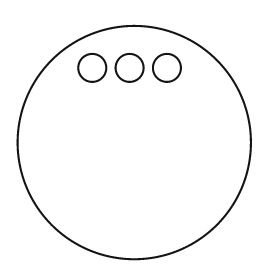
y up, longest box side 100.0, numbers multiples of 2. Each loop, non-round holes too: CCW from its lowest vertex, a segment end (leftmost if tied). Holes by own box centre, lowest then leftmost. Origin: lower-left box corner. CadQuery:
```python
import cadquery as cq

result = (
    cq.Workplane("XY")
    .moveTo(50.0, 50.0)
    .circle(50.0)
    .moveTo(32.0, 82.0)
    .circle(6.0)
    .moveTo(48.0, 82.0)
    .circle(6.0)
    .moveTo(64.0, 82.0)
    .circle(6.0)
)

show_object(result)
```